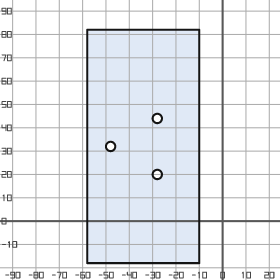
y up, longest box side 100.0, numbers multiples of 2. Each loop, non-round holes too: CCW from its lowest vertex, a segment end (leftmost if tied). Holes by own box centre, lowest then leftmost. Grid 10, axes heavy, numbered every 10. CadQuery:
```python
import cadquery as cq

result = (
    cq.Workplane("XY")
    .moveTo(-58.0, -18.0)
    .lineTo(-10.0, -18.0)
    .lineTo(-10.0, 82.0)
    .lineTo(-58.0, 82.0)
    .close()
    .moveTo(-28.0, 20.0)
    .circle(2.0)
    .moveTo(-48.0, 32.0)
    .circle(2.0)
    .moveTo(-28.0, 44.0)
    .circle(2.0)
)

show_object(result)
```